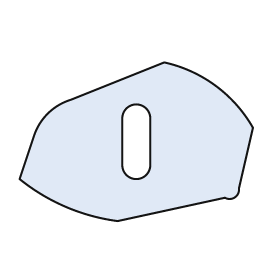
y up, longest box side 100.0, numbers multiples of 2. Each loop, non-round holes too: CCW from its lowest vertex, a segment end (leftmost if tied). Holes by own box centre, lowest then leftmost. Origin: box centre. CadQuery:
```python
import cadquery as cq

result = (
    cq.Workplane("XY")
    .moveTo(-8.0, -34.0)
    .lineTo(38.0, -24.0)
    .threePointArc((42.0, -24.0), (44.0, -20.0))
    .lineTo(50.0, 6.0)
    .threePointArc((34.0, 24.0), (12.0, 34.0))
    .lineTo(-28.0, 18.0)
    .threePointArc((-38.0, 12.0), (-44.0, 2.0))
    .lineTo(-50.0, -16.0)
    .threePointArc((-30.0, -28.0), (-8.0, -34.0))
    .close()
    .moveTo(-6.0, -10.0)
    .threePointArc((0.0, -16.0), (6.0, -10.0))
    .lineTo(6.0, 10.0)
    .threePointArc((0.0, 16.0), (-6.0, 10.0))
    .close()
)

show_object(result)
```